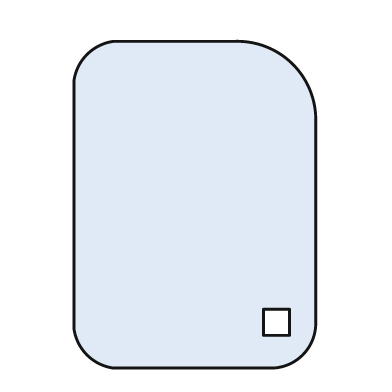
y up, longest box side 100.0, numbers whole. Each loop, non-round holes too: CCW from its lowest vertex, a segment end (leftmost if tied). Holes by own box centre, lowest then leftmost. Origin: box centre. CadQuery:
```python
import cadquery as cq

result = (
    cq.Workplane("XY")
    .moveTo(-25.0, -50.0)
    .lineTo(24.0, -50.0)
    .threePointArc((33.0, -46.0), (37.0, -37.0))
    .lineTo(37.0, 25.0)
    .threePointArc((30.0, 43.0), (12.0, 50.0))
    .lineTo(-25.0, 50.0)
    .threePointArc((-33.0, 46.0), (-37.0, 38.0))
    .lineTo(-37.0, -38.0)
    .threePointArc((-33.0, -46.0), (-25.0, -50.0))
    .close()
    .moveTo(21.0, -40.0)
    .lineTo(29.0, -40.0)
    .lineTo(29.0, -32.0)
    .lineTo(21.0, -32.0)
    .close()
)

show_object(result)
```